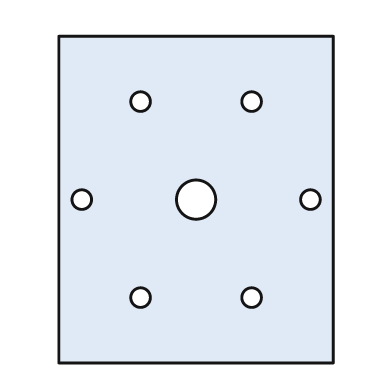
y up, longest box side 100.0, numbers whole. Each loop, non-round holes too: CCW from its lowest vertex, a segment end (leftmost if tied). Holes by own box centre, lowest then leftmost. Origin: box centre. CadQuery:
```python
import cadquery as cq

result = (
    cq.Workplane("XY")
    .moveTo(-42.0, -50.0)
    .lineTo(42.0, -50.0)
    .lineTo(42.0, 50.0)
    .lineTo(-42.0, 50.0)
    .close()
    .moveTo(-17.0, -30.0)
    .circle(3.0)
    .moveTo(17.0, -30.0)
    .circle(3.0)
    .moveTo(-35.0, 0.0)
    .circle(3.0)
    .moveTo(0.0, 0.0)
    .circle(6.0)
    .moveTo(35.0, 0.0)
    .circle(3.0)
    .moveTo(-17.0, 30.0)
    .circle(3.0)
    .moveTo(17.0, 30.0)
    .circle(3.0)
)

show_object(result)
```